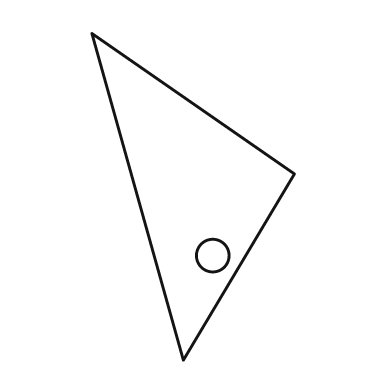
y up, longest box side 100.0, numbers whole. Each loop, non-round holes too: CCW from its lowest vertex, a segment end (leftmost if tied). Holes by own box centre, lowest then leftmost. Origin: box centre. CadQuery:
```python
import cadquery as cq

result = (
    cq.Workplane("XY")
    .moveTo(-3.0, -50.0)
    .lineTo(31.0, 7.0)
    .lineTo(-31.0, 50.0)
    .close()
    .moveTo(6.0, -18.0)
    .circle(5.0)
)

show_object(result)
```